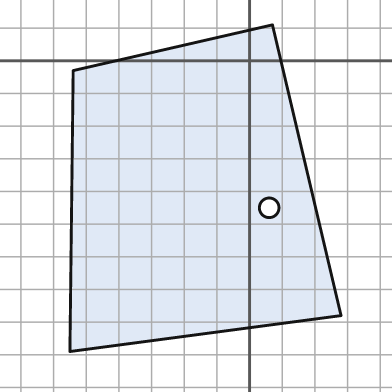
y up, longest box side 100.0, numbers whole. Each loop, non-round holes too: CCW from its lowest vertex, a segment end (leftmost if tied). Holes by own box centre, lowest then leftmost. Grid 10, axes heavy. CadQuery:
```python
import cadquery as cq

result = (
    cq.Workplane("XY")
    .moveTo(-55.0, -89.0)
    .lineTo(28.0, -78.0)
    .lineTo(7.0, 11.0)
    .lineTo(-54.0, -3.0)
    .close()
    .moveTo(6.0, -45.0)
    .circle(3.0)
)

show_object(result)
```